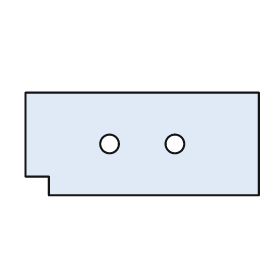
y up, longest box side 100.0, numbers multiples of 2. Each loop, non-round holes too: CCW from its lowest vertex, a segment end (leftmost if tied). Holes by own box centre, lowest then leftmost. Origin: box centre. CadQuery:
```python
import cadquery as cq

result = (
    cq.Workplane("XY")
    .moveTo(-40.0, -22.0)
    .lineTo(50.0, -22.0)
    .lineTo(50.0, 22.0)
    .lineTo(-50.0, 22.0)
    .lineTo(-50.0, -14.0)
    .lineTo(-40.0, -14.0)
    .close()
    .moveTo(-14.0, 0.0)
    .circle(4.0)
    .moveTo(14.0, 0.0)
    .circle(4.0)
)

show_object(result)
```